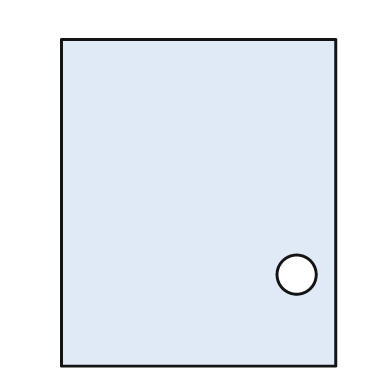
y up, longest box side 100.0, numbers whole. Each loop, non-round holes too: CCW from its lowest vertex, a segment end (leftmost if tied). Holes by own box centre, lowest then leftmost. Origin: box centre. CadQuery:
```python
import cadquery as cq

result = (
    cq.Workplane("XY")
    .moveTo(-42.0, -50.0)
    .lineTo(42.0, -50.0)
    .lineTo(42.0, 50.0)
    .lineTo(-42.0, 50.0)
    .close()
    .moveTo(30.0, -22.0)
    .circle(6.0)
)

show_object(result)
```